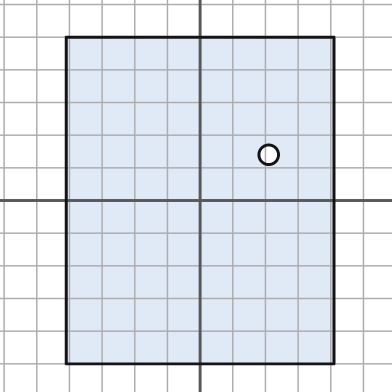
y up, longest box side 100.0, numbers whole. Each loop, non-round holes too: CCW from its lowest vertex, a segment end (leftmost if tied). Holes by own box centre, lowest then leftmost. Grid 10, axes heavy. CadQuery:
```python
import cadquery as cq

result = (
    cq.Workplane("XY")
    .moveTo(-41.0, -50.0)
    .lineTo(41.0, -50.0)
    .lineTo(41.0, 50.0)
    .lineTo(-41.0, 50.0)
    .close()
    .moveTo(21.0, 14.0)
    .circle(3.0)
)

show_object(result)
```